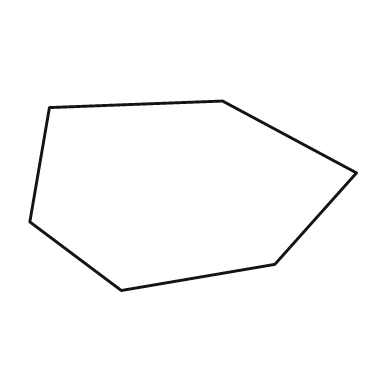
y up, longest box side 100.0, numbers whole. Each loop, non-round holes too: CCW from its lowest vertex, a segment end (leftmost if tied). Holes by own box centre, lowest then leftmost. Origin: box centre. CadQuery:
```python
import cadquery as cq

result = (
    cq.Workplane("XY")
    .moveTo(-22.0, -29.0)
    .lineTo(25.0, -21.0)
    .lineTo(50.0, 7.0)
    .lineTo(9.0, 29.0)
    .lineTo(-44.0, 27.0)
    .lineTo(-50.0, -8.0)
    .close()
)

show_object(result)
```